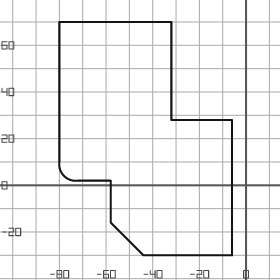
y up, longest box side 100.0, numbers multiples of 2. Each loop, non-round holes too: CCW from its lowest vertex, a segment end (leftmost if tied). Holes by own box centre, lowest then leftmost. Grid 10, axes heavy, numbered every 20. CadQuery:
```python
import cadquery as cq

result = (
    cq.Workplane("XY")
    .moveTo(-44.0, -30.0)
    .lineTo(-6.0, -30.0)
    .lineTo(-6.0, 28.0)
    .lineTo(-32.0, 28.0)
    .lineTo(-32.0, 70.0)
    .lineTo(-80.0, 70.0)
    .lineTo(-80.0, 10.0)
    .threePointArc((-78.0, 4.0), (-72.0, 2.0))
    .lineTo(-58.0, 2.0)
    .lineTo(-58.0, -16.0)
    .close()
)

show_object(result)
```